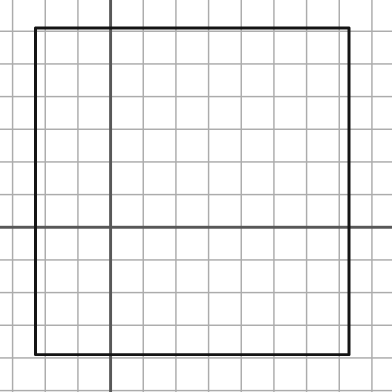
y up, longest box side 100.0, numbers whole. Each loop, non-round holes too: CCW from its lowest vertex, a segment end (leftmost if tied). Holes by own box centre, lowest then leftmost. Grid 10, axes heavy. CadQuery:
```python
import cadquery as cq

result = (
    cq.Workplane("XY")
    .moveTo(-23.0, -39.0)
    .lineTo(73.0, -39.0)
    .lineTo(73.0, 61.0)
    .lineTo(-23.0, 61.0)
    .close()
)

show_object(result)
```